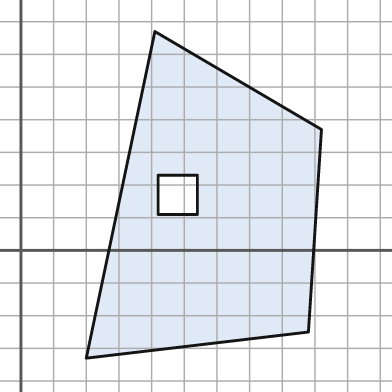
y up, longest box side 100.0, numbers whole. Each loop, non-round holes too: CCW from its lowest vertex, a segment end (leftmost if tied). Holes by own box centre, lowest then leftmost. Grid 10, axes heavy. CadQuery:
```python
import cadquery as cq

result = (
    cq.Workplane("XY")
    .moveTo(20.0, -33.0)
    .lineTo(88.0, -25.0)
    .lineTo(92.0, 37.0)
    .lineTo(41.0, 67.0)
    .close()
    .moveTo(42.0, 11.0)
    .lineTo(54.0, 11.0)
    .lineTo(54.0, 23.0)
    .lineTo(42.0, 23.0)
    .close()
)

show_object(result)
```